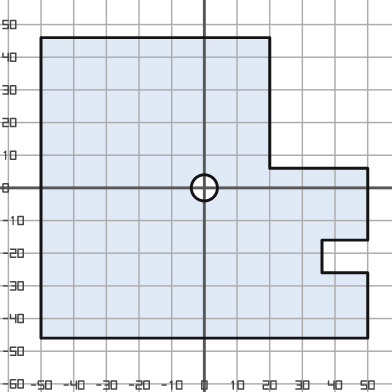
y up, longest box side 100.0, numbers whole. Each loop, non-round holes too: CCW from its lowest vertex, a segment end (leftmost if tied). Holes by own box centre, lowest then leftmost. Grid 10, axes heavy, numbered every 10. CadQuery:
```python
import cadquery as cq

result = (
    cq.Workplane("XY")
    .moveTo(-50.0, -46.0)
    .lineTo(50.0, -46.0)
    .lineTo(50.0, -26.0)
    .lineTo(36.0, -26.0)
    .lineTo(36.0, -16.0)
    .lineTo(50.0, -16.0)
    .lineTo(50.0, 6.0)
    .lineTo(20.0, 6.0)
    .lineTo(20.0, 46.0)
    .lineTo(-50.0, 46.0)
    .close()
    .moveTo(0.0, 0.0)
    .circle(4.0)
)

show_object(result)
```